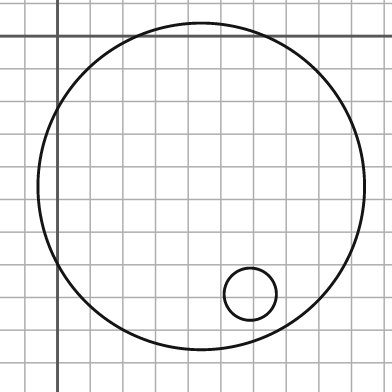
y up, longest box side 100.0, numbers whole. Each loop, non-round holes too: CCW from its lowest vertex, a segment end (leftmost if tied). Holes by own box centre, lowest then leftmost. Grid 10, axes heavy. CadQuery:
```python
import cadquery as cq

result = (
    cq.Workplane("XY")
    .moveTo(44.0, -46.0)
    .circle(50.0)
    .moveTo(59.0, -79.0)
    .circle(8.0)
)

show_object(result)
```